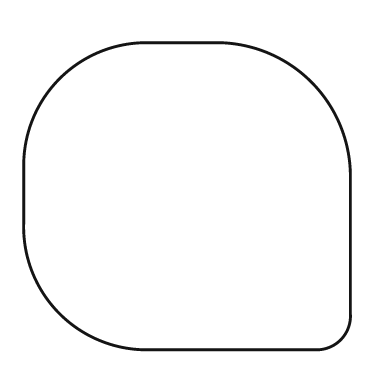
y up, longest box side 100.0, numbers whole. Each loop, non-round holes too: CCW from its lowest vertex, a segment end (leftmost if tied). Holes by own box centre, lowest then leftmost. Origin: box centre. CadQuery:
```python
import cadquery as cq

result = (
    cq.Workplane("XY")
    .moveTo(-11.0, -47.0)
    .lineTo(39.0, -47.0)
    .threePointArc((47.0, -44.0), (50.0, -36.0))
    .lineTo(50.0, 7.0)
    .threePointArc((38.0, 35.0), (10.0, 47.0))
    .lineTo(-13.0, 47.0)
    .threePointArc((-39.0, 36.0), (-50.0, 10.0))
    .lineTo(-50.0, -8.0)
    .threePointArc((-39.0, -36.0), (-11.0, -47.0))
    .close()
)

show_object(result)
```